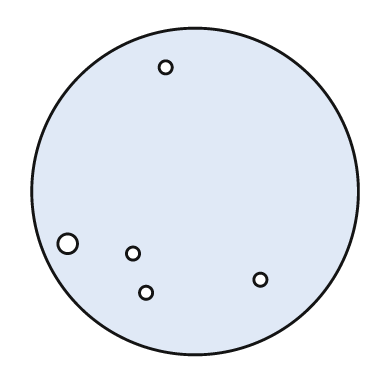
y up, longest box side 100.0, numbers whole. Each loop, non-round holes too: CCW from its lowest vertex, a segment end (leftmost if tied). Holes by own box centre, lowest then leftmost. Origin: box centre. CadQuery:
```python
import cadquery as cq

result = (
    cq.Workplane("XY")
    .moveTo(0.0, 0.0)
    .circle(50.0)
    .moveTo(-15.0, -31.0)
    .circle(2.0)
    .moveTo(20.0, -27.0)
    .circle(2.0)
    .moveTo(-19.0, -19.0)
    .circle(2.0)
    .moveTo(-39.0, -16.0)
    .circle(3.0)
    .moveTo(-9.0, 38.0)
    .circle(2.0)
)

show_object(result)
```